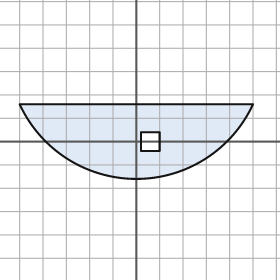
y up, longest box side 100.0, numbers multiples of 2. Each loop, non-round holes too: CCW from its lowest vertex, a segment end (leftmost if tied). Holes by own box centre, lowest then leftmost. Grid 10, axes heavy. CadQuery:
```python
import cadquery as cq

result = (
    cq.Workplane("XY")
    .moveTo(-50.0, 16.0)
    .threePointArc((0.0, -16.0), (50.0, 16.0))
    .close()
    .moveTo(2.0, -4.0)
    .lineTo(10.0, -4.0)
    .lineTo(10.0, 4.0)
    .lineTo(2.0, 4.0)
    .close()
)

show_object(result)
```